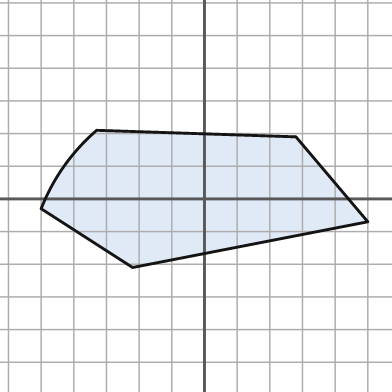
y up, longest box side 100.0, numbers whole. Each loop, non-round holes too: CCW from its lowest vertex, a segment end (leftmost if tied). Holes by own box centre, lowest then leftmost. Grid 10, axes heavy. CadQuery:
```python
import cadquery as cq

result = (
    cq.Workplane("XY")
    .moveTo(-22.0, -21.0)
    .lineTo(50.0, -7.0)
    .lineTo(28.0, 19.0)
    .lineTo(-33.0, 21.0)
    .threePointArc((-43.0, 10.0), (-50.0, -3.0))
    .close()
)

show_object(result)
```